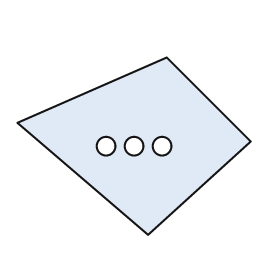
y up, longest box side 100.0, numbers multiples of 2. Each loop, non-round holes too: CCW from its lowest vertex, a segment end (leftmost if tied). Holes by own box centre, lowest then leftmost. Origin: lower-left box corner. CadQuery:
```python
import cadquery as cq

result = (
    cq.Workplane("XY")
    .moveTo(56.0, 0.0)
    .lineTo(100.0, 40.0)
    .lineTo(64.0, 76.0)
    .lineTo(0.0, 48.0)
    .close()
    .moveTo(38.0, 38.0)
    .circle(4.0)
    .moveTo(50.0, 38.0)
    .circle(4.0)
    .moveTo(62.0, 38.0)
    .circle(4.0)
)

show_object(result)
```